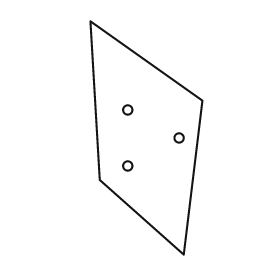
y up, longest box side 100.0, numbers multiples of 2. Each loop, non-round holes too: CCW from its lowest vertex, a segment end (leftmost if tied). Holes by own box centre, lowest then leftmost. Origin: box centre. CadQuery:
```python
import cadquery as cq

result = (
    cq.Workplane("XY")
    .moveTo(16.0, -50.0)
    .lineTo(24.0, 16.0)
    .lineTo(-24.0, 50.0)
    .lineTo(-20.0, -18.0)
    .close()
    .moveTo(-8.0, -12.0)
    .circle(2.0)
    .moveTo(14.0, 0.0)
    .circle(2.0)
    .moveTo(-8.0, 12.0)
    .circle(2.0)
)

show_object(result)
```